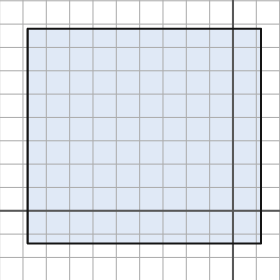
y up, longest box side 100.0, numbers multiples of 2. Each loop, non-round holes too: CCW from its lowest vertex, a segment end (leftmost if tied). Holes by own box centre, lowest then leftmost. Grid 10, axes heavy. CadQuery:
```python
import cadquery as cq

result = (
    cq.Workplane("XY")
    .moveTo(-88.0, -14.0)
    .lineTo(12.0, -14.0)
    .lineTo(12.0, 78.0)
    .lineTo(-88.0, 78.0)
    .close()
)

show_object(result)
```